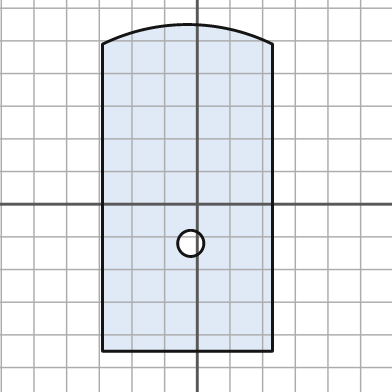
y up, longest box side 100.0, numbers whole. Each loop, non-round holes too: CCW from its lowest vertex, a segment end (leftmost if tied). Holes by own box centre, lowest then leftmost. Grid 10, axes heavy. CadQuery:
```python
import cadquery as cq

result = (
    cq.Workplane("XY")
    .moveTo(-29.0, -45.0)
    .lineTo(23.0, -45.0)
    .lineTo(23.0, 49.0)
    .threePointArc((-3.0, 55.0), (-29.0, 49.0))
    .close()
    .moveTo(-2.0, -12.0)
    .circle(4.0)
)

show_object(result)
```